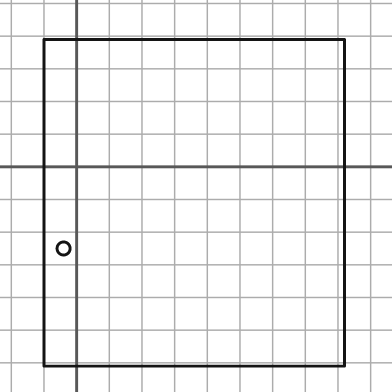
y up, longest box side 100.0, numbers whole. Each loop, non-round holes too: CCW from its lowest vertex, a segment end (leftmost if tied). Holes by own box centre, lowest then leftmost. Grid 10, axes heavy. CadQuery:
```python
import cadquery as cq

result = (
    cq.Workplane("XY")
    .moveTo(-10.0, -61.0)
    .lineTo(82.0, -61.0)
    .lineTo(82.0, 39.0)
    .lineTo(-10.0, 39.0)
    .close()
    .moveTo(-4.0, -25.0)
    .circle(2.0)
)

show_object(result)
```